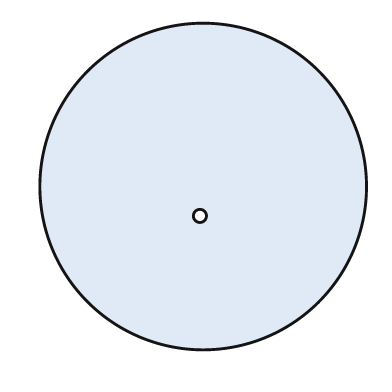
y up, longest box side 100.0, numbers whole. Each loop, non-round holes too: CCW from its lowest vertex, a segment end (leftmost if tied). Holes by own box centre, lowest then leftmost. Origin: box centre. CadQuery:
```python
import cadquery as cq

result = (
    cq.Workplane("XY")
    .moveTo(0.0, 0.0)
    .circle(50.0)
    .moveTo(-1.0, -9.0)
    .circle(2.0)
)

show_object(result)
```